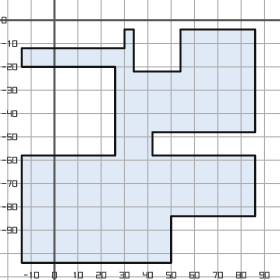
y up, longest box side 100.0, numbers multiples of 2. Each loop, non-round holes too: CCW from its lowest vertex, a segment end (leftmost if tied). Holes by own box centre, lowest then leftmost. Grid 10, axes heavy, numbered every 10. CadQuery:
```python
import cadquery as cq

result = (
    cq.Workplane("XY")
    .moveTo(-14.0, -104.0)
    .lineTo(50.0, -104.0)
    .lineTo(50.0, -84.0)
    .lineTo(86.0, -84.0)
    .lineTo(86.0, -58.0)
    .lineTo(42.0, -58.0)
    .lineTo(42.0, -48.0)
    .lineTo(86.0, -48.0)
    .lineTo(86.0, -4.0)
    .lineTo(54.0, -4.0)
    .lineTo(54.0, -22.0)
    .lineTo(34.0, -22.0)
    .lineTo(34.0, -4.0)
    .lineTo(30.0, -4.0)
    .lineTo(30.0, -12.0)
    .lineTo(-14.0, -12.0)
    .lineTo(-14.0, -20.0)
    .lineTo(26.0, -20.0)
    .lineTo(26.0, -58.0)
    .lineTo(-14.0, -58.0)
    .close()
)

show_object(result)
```